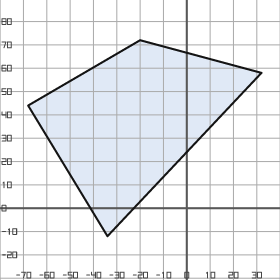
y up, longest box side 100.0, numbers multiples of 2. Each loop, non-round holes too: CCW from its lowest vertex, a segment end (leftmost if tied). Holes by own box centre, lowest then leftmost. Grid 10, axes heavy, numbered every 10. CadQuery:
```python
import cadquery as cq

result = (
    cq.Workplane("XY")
    .moveTo(-34.0, -12.0)
    .lineTo(32.0, 58.0)
    .lineTo(-20.0, 72.0)
    .lineTo(-68.0, 44.0)
    .close()
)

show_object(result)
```